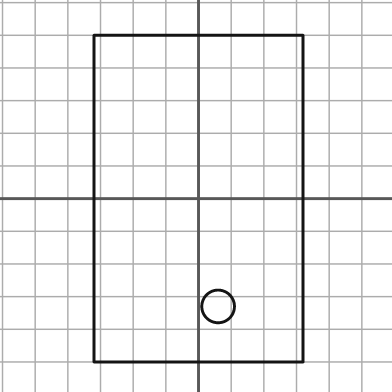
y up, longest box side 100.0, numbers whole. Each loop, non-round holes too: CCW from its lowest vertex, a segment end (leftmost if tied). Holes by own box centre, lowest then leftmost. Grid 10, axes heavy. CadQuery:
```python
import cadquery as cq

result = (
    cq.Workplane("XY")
    .moveTo(-32.0, -50.0)
    .lineTo(32.0, -50.0)
    .lineTo(32.0, 50.0)
    .lineTo(-32.0, 50.0)
    .close()
    .moveTo(6.0, -33.0)
    .circle(5.0)
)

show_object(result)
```